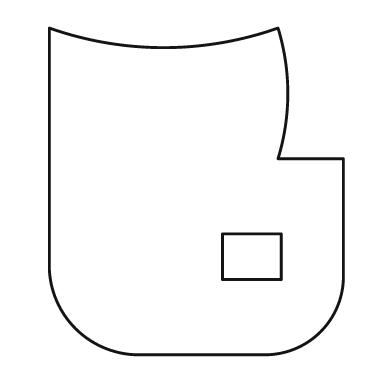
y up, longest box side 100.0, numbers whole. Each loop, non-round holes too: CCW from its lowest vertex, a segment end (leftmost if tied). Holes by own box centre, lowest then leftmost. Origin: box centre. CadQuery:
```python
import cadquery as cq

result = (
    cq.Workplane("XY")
    .moveTo(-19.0, -50.0)
    .lineTo(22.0, -50.0)
    .threePointArc((38.0, -43.0), (45.0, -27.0))
    .lineTo(45.0, 10.0)
    .lineTo(25.0, 10.0)
    .threePointArc((28.0, 30.0), (25.0, 50.0))
    .threePointArc((-10.0, 44.0), (-45.0, 50.0))
    .lineTo(-45.0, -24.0)
    .threePointArc((-37.0, -42.0), (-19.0, -50.0))
    .close()
    .moveTo(8.0, -27.0)
    .lineTo(26.0, -27.0)
    .lineTo(26.0, -13.0)
    .lineTo(8.0, -13.0)
    .close()
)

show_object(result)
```